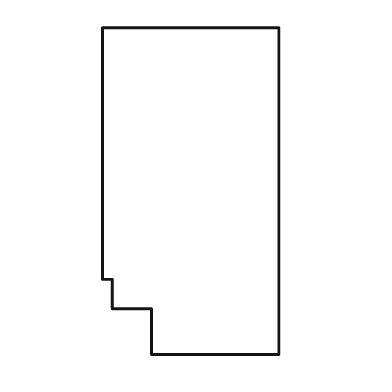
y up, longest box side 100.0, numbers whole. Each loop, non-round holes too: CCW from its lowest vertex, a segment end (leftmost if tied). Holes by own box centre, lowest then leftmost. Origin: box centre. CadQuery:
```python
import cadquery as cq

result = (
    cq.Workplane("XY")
    .moveTo(-12.0, -50.0)
    .lineTo(27.0, -50.0)
    .lineTo(27.0, 50.0)
    .lineTo(-27.0, 50.0)
    .lineTo(-27.0, -27.0)
    .lineTo(-24.0, -27.0)
    .lineTo(-24.0, -36.0)
    .lineTo(-12.0, -36.0)
    .close()
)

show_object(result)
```